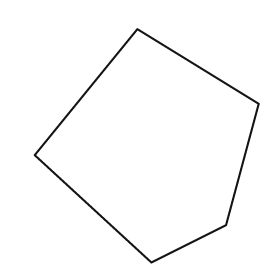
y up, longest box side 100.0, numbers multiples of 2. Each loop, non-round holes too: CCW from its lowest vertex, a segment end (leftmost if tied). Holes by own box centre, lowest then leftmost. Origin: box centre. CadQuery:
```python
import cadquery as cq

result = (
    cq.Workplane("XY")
    .moveTo(2.0, -50.0)
    .lineTo(34.0, -34.0)
    .lineTo(48.0, 18.0)
    .lineTo(-4.0, 50.0)
    .lineTo(-48.0, -4.0)
    .close()
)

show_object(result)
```